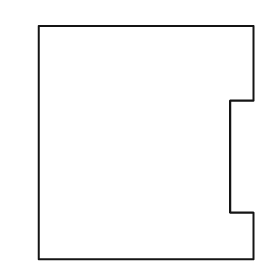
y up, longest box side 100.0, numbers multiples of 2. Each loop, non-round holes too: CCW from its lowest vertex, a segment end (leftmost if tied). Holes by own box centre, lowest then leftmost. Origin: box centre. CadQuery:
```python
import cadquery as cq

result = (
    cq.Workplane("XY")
    .moveTo(-46.0, -50.0)
    .lineTo(46.0, -50.0)
    .lineTo(46.0, -30.0)
    .lineTo(36.0, -30.0)
    .lineTo(36.0, 18.0)
    .lineTo(46.0, 18.0)
    .lineTo(46.0, 50.0)
    .lineTo(-46.0, 50.0)
    .close()
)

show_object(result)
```